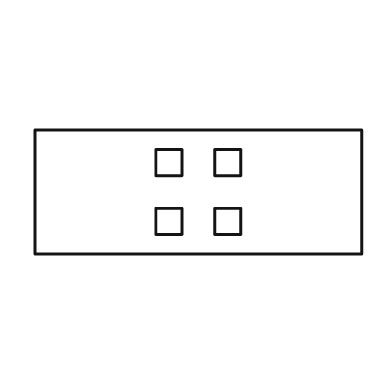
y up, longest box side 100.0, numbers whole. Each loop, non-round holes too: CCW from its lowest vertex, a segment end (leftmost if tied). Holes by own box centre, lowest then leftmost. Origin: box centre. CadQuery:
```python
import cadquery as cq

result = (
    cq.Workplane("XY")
    .moveTo(-50.0, -19.0)
    .lineTo(50.0, -19.0)
    .lineTo(50.0, 19.0)
    .lineTo(-50.0, 19.0)
    .close()
    .moveTo(-13.0, -13.0)
    .lineTo(-5.0, -13.0)
    .lineTo(-5.0, -5.0)
    .lineTo(-13.0, -5.0)
    .close()
    .moveTo(5.0, -13.0)
    .lineTo(13.0, -13.0)
    .lineTo(13.0, -5.0)
    .lineTo(5.0, -5.0)
    .close()
    .moveTo(-13.0, 5.0)
    .lineTo(-5.0, 5.0)
    .lineTo(-5.0, 13.0)
    .lineTo(-13.0, 13.0)
    .close()
    .moveTo(5.0, 5.0)
    .lineTo(13.0, 5.0)
    .lineTo(13.0, 13.0)
    .lineTo(5.0, 13.0)
    .close()
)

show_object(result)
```